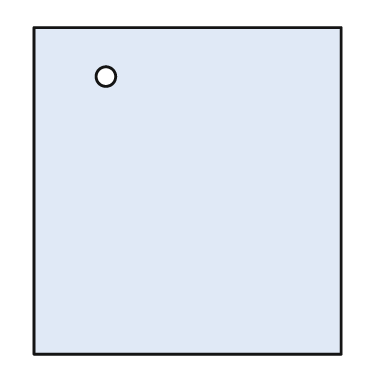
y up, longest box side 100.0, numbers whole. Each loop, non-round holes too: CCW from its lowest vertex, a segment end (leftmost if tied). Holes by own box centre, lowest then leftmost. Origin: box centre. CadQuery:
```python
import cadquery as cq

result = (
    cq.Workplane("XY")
    .moveTo(-47.0, -50.0)
    .lineTo(47.0, -50.0)
    .lineTo(47.0, 50.0)
    .lineTo(-47.0, 50.0)
    .close()
    .moveTo(-25.0, 35.0)
    .circle(3.0)
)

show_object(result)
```